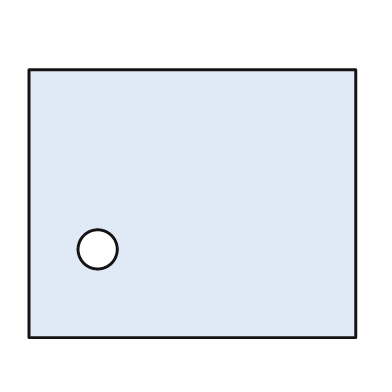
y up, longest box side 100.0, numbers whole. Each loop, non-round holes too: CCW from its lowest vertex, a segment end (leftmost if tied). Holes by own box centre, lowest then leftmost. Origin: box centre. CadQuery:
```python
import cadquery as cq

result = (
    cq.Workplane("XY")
    .moveTo(-50.0, -41.0)
    .lineTo(50.0, -41.0)
    .lineTo(50.0, 41.0)
    .lineTo(-50.0, 41.0)
    .close()
    .moveTo(-29.0, -14.0)
    .circle(6.0)
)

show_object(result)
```